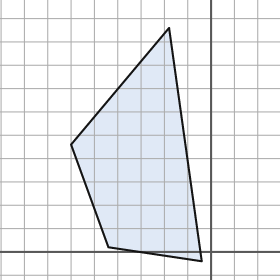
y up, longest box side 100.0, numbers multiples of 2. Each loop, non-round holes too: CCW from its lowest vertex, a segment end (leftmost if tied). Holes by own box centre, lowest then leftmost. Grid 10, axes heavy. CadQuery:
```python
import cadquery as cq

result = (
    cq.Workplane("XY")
    .moveTo(-4.0, -4.0)
    .lineTo(-18.0, 96.0)
    .lineTo(-60.0, 46.0)
    .lineTo(-44.0, 2.0)
    .close()
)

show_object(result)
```